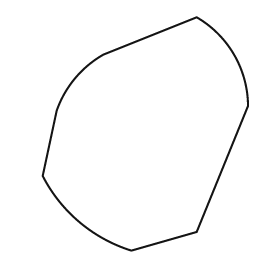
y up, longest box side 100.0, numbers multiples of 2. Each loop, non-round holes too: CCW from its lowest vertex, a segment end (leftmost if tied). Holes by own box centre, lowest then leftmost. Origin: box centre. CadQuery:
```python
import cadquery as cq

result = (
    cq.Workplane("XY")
    .moveTo(-6.0, -50.0)
    .lineTo(22.0, -42.0)
    .lineTo(44.0, 12.0)
    .threePointArc((38.0, 34.0), (22.0, 50.0))
    .lineTo(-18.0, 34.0)
    .threePointArc((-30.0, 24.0), (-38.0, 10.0))
    .lineTo(-44.0, -18.0)
    .threePointArc((-28.0, -38.0), (-6.0, -50.0))
    .close()
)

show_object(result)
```